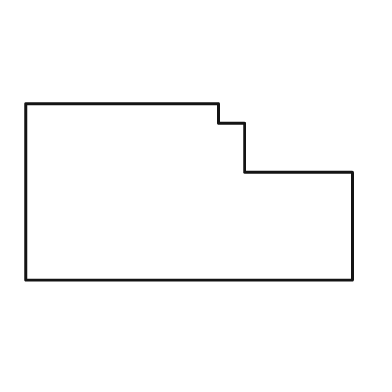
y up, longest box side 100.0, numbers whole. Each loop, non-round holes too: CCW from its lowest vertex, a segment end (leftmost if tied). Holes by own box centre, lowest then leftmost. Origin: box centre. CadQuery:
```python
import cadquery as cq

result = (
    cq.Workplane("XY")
    .moveTo(-50.0, -27.0)
    .lineTo(50.0, -27.0)
    .lineTo(50.0, 6.0)
    .lineTo(17.0, 6.0)
    .lineTo(17.0, 21.0)
    .lineTo(9.0, 21.0)
    .lineTo(9.0, 27.0)
    .lineTo(-50.0, 27.0)
    .close()
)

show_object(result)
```